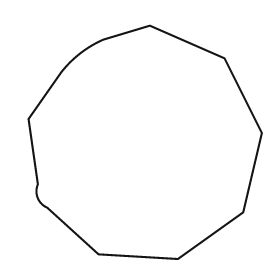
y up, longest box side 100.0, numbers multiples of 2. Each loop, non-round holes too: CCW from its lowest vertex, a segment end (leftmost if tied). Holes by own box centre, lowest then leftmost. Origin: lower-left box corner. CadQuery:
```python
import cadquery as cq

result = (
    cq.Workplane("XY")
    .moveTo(64.0, 0.0)
    .lineTo(92.0, 20.0)
    .lineTo(100.0, 54.0)
    .lineTo(84.0, 86.0)
    .lineTo(52.0, 100.0)
    .lineTo(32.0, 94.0)
    .threePointArc((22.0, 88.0), (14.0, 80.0))
    .lineTo(0.0, 60.0)
    .lineTo(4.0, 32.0)
    .threePointArc((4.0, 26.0), (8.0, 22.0))
    .lineTo(30.0, 2.0)
    .close()
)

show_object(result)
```